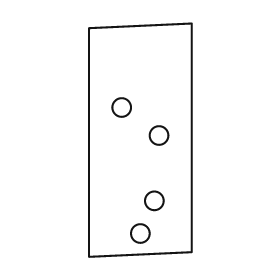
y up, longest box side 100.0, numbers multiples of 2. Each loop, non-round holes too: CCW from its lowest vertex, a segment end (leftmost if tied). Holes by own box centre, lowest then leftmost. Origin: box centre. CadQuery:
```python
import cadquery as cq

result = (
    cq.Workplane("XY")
    .moveTo(-22.0, -50.0)
    .lineTo(22.0, -48.0)
    .lineTo(22.0, 50.0)
    .lineTo(-22.0, 48.0)
    .close()
    .moveTo(0.0, -40.0)
    .circle(4.0)
    .moveTo(6.0, -26.0)
    .circle(4.0)
    .moveTo(8.0, 2.0)
    .circle(4.0)
    .moveTo(-8.0, 14.0)
    .circle(4.0)
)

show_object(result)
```